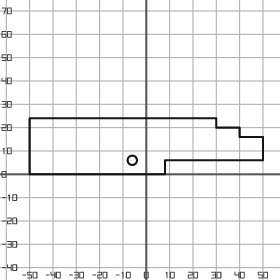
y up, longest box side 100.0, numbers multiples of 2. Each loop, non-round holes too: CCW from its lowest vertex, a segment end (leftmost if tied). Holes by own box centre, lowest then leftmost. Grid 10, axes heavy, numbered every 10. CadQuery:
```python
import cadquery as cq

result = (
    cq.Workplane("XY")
    .moveTo(-50.0, 0.0)
    .lineTo(8.0, 0.0)
    .lineTo(8.0, 6.0)
    .lineTo(50.0, 6.0)
    .lineTo(50.0, 16.0)
    .lineTo(40.0, 16.0)
    .lineTo(40.0, 20.0)
    .lineTo(30.0, 20.0)
    .lineTo(30.0, 24.0)
    .lineTo(-50.0, 24.0)
    .close()
    .moveTo(-6.0, 6.0)
    .circle(2.0)
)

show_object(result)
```